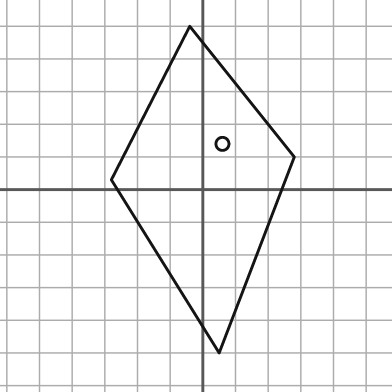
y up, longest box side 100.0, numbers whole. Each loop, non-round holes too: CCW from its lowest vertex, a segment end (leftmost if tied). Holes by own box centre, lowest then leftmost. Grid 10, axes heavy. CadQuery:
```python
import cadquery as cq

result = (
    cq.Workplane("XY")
    .moveTo(5.0, -50.0)
    .lineTo(28.0, 10.0)
    .lineTo(-4.0, 50.0)
    .lineTo(-28.0, 3.0)
    .close()
    .moveTo(6.0, 14.0)
    .circle(2.0)
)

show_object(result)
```